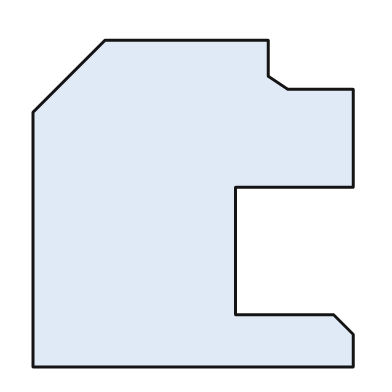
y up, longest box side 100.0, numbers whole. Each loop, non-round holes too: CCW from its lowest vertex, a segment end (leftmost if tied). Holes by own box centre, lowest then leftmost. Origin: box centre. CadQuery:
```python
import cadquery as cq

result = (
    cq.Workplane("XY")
    .moveTo(-49.0, -50.0)
    .lineTo(49.0, -50.0)
    .lineTo(49.0, -40.0)
    .lineTo(43.0, -34.0)
    .lineTo(13.0, -34.0)
    .lineTo(13.0, 5.0)
    .lineTo(49.0, 5.0)
    .lineTo(49.0, 35.0)
    .lineTo(29.0, 35.0)
    .lineTo(23.0, 39.0)
    .lineTo(23.0, 50.0)
    .lineTo(-27.0, 50.0)
    .lineTo(-49.0, 28.0)
    .close()
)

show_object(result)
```